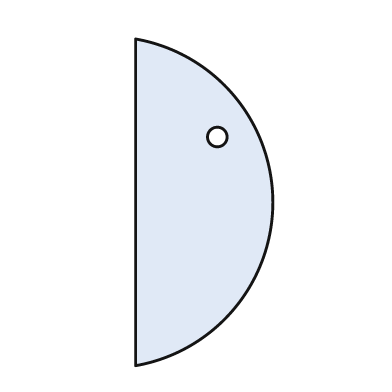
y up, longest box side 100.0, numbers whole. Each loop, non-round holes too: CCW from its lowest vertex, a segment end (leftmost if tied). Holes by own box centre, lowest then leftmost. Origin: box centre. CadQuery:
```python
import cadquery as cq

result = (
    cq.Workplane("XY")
    .moveTo(-21.0, -50.0)
    .threePointArc((21.0, 0.0), (-21.0, 50.0))
    .close()
    .moveTo(4.0, 20.0)
    .circle(3.0)
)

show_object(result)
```